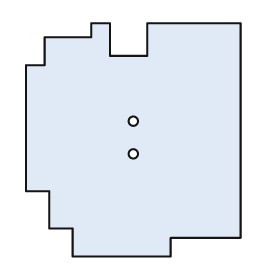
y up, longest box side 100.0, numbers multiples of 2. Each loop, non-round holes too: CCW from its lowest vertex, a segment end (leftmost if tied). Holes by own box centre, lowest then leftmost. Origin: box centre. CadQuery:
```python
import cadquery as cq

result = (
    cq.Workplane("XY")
    .moveTo(-26.0, -50.0)
    .lineTo(16.0, -50.0)
    .lineTo(16.0, -42.0)
    .lineTo(46.0, -42.0)
    .lineTo(46.0, 50.0)
    .lineTo(6.0, 50.0)
    .lineTo(6.0, 36.0)
    .lineTo(-10.0, 36.0)
    .lineTo(-10.0, 50.0)
    .lineTo(-18.0, 50.0)
    .lineTo(-18.0, 44.0)
    .lineTo(-38.0, 44.0)
    .lineTo(-38.0, 32.0)
    .lineTo(-46.0, 32.0)
    .lineTo(-46.0, -22.0)
    .lineTo(-36.0, -22.0)
    .lineTo(-36.0, -38.0)
    .lineTo(-26.0, -38.0)
    .close()
    .moveTo(0.0, -6.0)
    .circle(2.0)
    .moveTo(0.0, 8.0)
    .circle(2.0)
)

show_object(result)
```